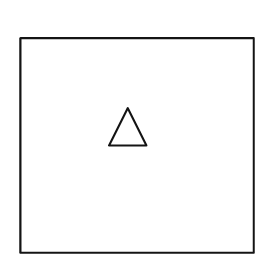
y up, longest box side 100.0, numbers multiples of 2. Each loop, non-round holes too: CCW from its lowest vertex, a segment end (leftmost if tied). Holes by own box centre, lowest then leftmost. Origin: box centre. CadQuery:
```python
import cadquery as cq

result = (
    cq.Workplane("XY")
    .moveTo(-50.0, -46.0)
    .lineTo(50.0, -46.0)
    .lineTo(50.0, 46.0)
    .lineTo(-50.0, 46.0)
    .close()
    .moveTo(-12.0, 0.0)
    .lineTo(4.0, 0.0)
    .lineTo(-4.0, 16.0)
    .close()
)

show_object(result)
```